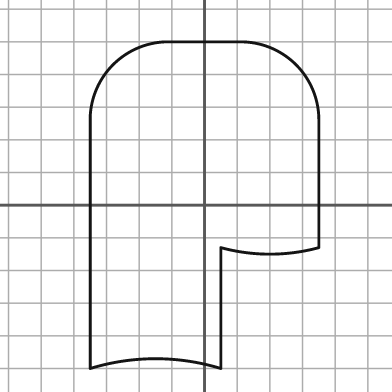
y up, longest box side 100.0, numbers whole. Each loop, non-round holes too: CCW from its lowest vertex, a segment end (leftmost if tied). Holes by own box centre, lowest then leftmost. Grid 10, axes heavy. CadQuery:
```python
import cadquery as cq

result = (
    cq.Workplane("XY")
    .moveTo(-35.0, -50.0)
    .threePointArc((-15.0, -47.0), (5.0, -50.0))
    .lineTo(5.0, -13.0)
    .threePointArc((20.0, -15.0), (35.0, -13.0))
    .lineTo(35.0, 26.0)
    .threePointArc((28.0, 43.0), (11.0, 50.0))
    .lineTo(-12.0, 50.0)
    .threePointArc((-28.0, 43.0), (-35.0, 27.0))
    .close()
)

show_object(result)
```